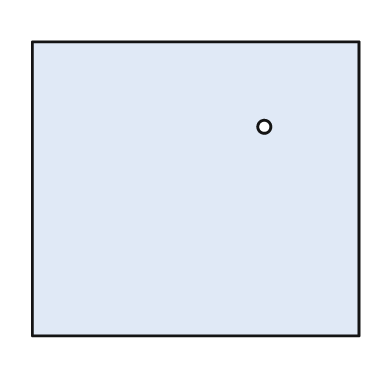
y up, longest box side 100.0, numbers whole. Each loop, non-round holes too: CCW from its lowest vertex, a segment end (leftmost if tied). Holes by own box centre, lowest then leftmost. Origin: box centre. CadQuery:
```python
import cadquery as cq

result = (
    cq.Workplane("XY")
    .moveTo(-50.0, -45.0)
    .lineTo(50.0, -45.0)
    .lineTo(50.0, 45.0)
    .lineTo(-50.0, 45.0)
    .close()
    .moveTo(21.0, 19.0)
    .circle(2.0)
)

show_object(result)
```